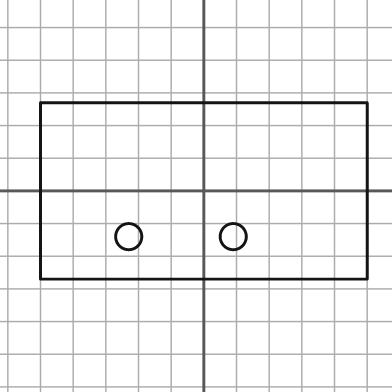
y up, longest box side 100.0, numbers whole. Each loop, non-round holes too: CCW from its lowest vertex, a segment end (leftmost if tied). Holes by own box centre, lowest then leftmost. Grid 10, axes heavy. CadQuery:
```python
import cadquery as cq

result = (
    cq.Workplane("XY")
    .moveTo(-50.0, -27.0)
    .lineTo(50.0, -27.0)
    .lineTo(50.0, 27.0)
    .lineTo(-50.0, 27.0)
    .close()
    .moveTo(-23.0, -14.0)
    .circle(4.0)
    .moveTo(9.0, -14.0)
    .circle(4.0)
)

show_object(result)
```